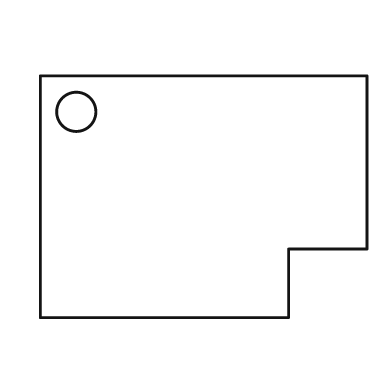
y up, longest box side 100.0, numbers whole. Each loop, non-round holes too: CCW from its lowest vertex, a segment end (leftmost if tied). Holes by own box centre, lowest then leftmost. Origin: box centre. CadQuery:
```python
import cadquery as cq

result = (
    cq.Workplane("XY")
    .moveTo(-50.0, -37.0)
    .lineTo(26.0, -37.0)
    .lineTo(26.0, -16.0)
    .lineTo(50.0, -16.0)
    .lineTo(50.0, 37.0)
    .lineTo(-50.0, 37.0)
    .close()
    .moveTo(-39.0, 26.0)
    .circle(6.0)
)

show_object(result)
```